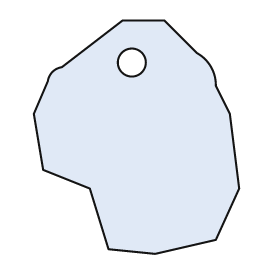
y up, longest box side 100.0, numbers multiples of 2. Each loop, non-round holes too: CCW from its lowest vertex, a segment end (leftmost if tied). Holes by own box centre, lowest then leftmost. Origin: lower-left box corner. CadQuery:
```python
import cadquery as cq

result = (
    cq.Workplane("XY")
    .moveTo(52.0, 0.0)
    .lineTo(78.0, 6.0)
    .lineTo(88.0, 28.0)
    .lineTo(84.0, 60.0)
    .lineTo(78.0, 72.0)
    .threePointArc((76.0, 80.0), (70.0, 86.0))
    .lineTo(56.0, 100.0)
    .lineTo(38.0, 100.0)
    .lineTo(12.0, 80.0)
    .threePointArc((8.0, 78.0), (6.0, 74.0))
    .lineTo(0.0, 60.0)
    .lineTo(4.0, 36.0)
    .lineTo(24.0, 28.0)
    .lineTo(32.0, 2.0)
    .close()
    .moveTo(42.0, 82.0)
    .circle(6.0)
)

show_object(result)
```